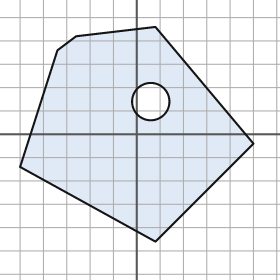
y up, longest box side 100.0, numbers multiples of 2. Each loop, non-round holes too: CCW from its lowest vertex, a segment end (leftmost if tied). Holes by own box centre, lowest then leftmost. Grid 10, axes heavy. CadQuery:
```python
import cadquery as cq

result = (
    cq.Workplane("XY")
    .moveTo(8.0, -46.0)
    .lineTo(50.0, -4.0)
    .lineTo(8.0, 46.0)
    .lineTo(-26.0, 42.0)
    .lineTo(-34.0, 36.0)
    .lineTo(-50.0, -14.0)
    .close()
    .moveTo(6.0, 14.0)
    .circle(8.0)
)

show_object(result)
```